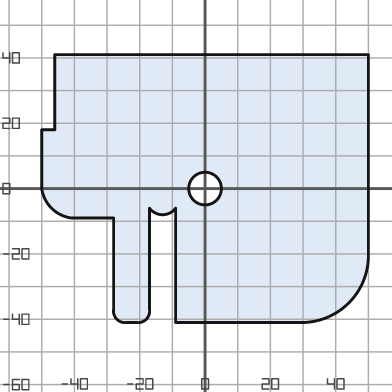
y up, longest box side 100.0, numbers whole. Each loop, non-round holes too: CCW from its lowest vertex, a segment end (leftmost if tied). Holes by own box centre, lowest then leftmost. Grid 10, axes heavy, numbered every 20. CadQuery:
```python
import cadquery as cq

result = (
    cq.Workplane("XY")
    .moveTo(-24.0, -41.0)
    .lineTo(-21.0, -41.0)
    .threePointArc((-18.0, -40.0), (-17.0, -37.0))
    .lineTo(-17.0, -6.0)
    .threePointArc((-13.0, -8.0), (-9.0, -6.0))
    .lineTo(-9.0, -41.0)
    .lineTo(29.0, -41.0)
    .threePointArc((44.0, -35.0), (50.0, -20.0))
    .lineTo(50.0, 41.0)
    .lineTo(-46.0, 41.0)
    .lineTo(-46.0, 18.0)
    .lineTo(-50.0, 18.0)
    .lineTo(-50.0, 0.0)
    .threePointArc((-47.0, -6.0), (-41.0, -9.0))
    .lineTo(-28.0, -9.0)
    .lineTo(-28.0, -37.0)
    .threePointArc((-27.0, -40.0), (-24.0, -41.0))
    .close()
    .moveTo(0.0, 0.0)
    .circle(5.0)
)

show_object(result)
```